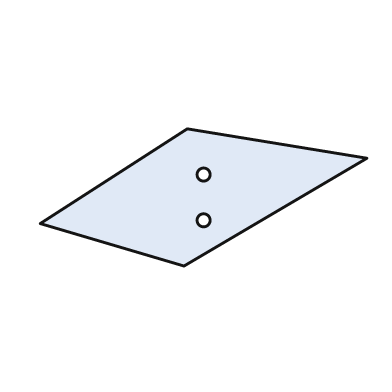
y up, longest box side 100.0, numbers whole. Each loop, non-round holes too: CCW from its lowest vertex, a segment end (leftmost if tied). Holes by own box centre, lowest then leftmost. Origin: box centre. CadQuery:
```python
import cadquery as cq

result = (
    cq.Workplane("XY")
    .moveTo(-6.0, -21.0)
    .lineTo(50.0, 12.0)
    .lineTo(-5.0, 21.0)
    .lineTo(-50.0, -8.0)
    .close()
    .moveTo(0.0, -7.0)
    .circle(2.0)
    .moveTo(0.0, 7.0)
    .circle(2.0)
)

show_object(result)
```